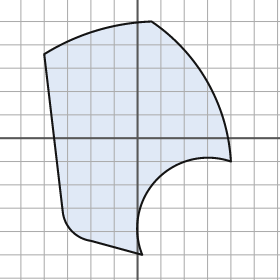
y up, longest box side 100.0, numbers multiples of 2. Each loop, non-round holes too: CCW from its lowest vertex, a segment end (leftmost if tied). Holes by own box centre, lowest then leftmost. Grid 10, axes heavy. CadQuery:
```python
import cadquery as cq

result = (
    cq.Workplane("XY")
    .moveTo(2.0, -50.0)
    .threePointArc((8.0, -18.0), (40.0, -10.0))
    .threePointArc((30.0, 24.0), (6.0, 50.0))
    .threePointArc((-18.0, 46.0), (-40.0, 36.0))
    .lineTo(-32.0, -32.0)
    .threePointArc((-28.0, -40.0), (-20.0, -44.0))
    .close()
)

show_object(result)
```